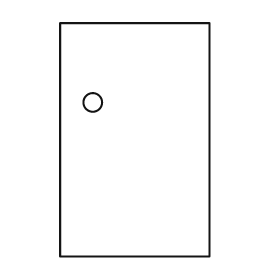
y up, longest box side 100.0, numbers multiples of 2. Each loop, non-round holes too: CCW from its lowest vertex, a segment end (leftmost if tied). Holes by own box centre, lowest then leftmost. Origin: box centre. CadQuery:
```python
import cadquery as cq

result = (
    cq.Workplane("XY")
    .moveTo(-32.0, -50.0)
    .lineTo(32.0, -50.0)
    .lineTo(32.0, 50.0)
    .lineTo(-32.0, 50.0)
    .close()
    .moveTo(-18.0, 16.0)
    .circle(4.0)
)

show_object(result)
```